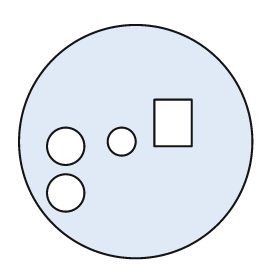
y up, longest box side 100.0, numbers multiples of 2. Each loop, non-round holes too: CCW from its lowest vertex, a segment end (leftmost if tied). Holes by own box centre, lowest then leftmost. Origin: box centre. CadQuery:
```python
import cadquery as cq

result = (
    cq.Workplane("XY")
    .moveTo(0.0, 0.0)
    .circle(50.0)
    .moveTo(-30.0, -22.0)
    .circle(8.0)
    .moveTo(-30.0, -2.0)
    .circle(8.0)
    .moveTo(-6.0, 0.0)
    .circle(6.0)
    .moveTo(8.0, -2.0)
    .lineTo(24.0, -2.0)
    .lineTo(24.0, 18.0)
    .lineTo(8.0, 18.0)
    .close()
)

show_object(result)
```